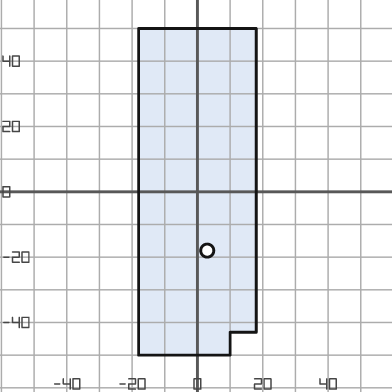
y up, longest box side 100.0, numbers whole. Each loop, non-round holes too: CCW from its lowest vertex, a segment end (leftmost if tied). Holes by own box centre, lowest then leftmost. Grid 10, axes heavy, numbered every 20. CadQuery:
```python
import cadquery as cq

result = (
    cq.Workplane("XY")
    .moveTo(-18.0, -50.0)
    .lineTo(10.0, -50.0)
    .lineTo(10.0, -43.0)
    .lineTo(18.0, -43.0)
    .lineTo(18.0, 50.0)
    .lineTo(-18.0, 50.0)
    .close()
    .moveTo(3.0, -18.0)
    .circle(2.0)
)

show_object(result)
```